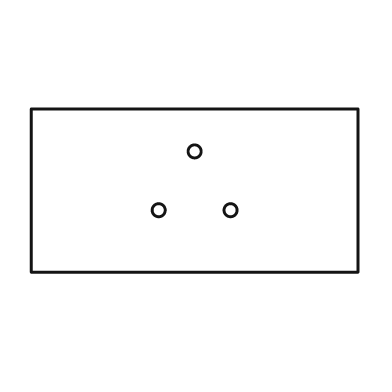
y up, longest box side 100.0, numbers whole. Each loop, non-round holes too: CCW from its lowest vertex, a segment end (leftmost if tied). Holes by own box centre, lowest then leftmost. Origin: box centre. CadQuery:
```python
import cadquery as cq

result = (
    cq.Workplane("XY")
    .moveTo(-50.0, -25.0)
    .lineTo(50.0, -25.0)
    .lineTo(50.0, 25.0)
    .lineTo(-50.0, 25.0)
    .close()
    .moveTo(-11.0, -6.0)
    .circle(2.0)
    .moveTo(11.0, -6.0)
    .circle(2.0)
    .moveTo(0.0, 12.0)
    .circle(2.0)
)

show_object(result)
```